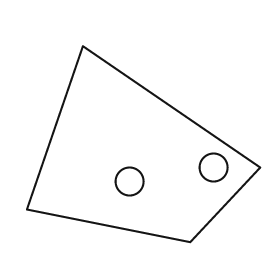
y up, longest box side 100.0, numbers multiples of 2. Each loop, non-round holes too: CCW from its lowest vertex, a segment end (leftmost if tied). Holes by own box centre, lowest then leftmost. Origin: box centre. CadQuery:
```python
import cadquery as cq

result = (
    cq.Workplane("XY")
    .moveTo(20.0, -42.0)
    .lineTo(50.0, -10.0)
    .lineTo(-26.0, 42.0)
    .lineTo(-50.0, -28.0)
    .close()
    .moveTo(-6.0, -16.0)
    .circle(6.0)
    .moveTo(30.0, -10.0)
    .circle(6.0)
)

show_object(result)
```